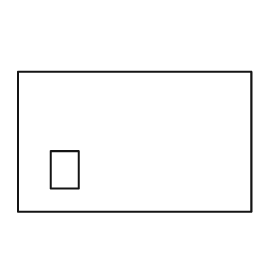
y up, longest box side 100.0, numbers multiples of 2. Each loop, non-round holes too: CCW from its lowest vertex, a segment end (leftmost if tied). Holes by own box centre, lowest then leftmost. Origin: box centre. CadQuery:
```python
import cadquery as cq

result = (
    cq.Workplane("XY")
    .moveTo(-50.0, -30.0)
    .lineTo(50.0, -30.0)
    .lineTo(50.0, 30.0)
    .lineTo(-50.0, 30.0)
    .close()
    .moveTo(-36.0, -20.0)
    .lineTo(-24.0, -20.0)
    .lineTo(-24.0, -4.0)
    .lineTo(-36.0, -4.0)
    .close()
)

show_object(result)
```